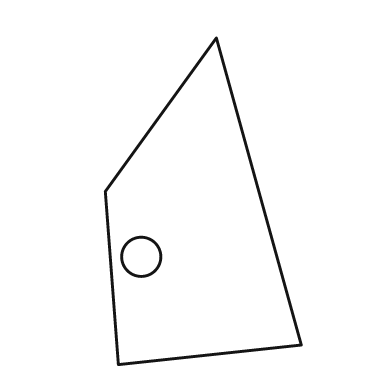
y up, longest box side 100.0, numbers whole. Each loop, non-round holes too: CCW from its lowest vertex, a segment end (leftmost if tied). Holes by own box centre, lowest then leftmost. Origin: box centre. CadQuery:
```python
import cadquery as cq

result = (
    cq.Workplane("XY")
    .moveTo(-26.0, -50.0)
    .lineTo(30.0, -44.0)
    .lineTo(4.0, 50.0)
    .lineTo(-30.0, 3.0)
    .close()
    .moveTo(-19.0, -17.0)
    .circle(6.0)
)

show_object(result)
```